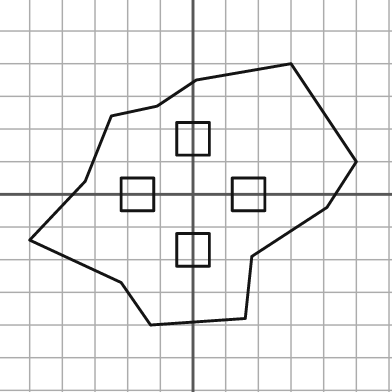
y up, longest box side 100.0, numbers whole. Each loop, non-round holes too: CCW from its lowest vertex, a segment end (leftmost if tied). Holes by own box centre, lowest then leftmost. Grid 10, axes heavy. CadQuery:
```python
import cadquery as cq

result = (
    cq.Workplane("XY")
    .moveTo(-13.0, -40.0)
    .lineTo(16.0, -38.0)
    .lineTo(18.0, -19.0)
    .lineTo(41.0, -4.0)
    .lineTo(50.0, 10.0)
    .lineTo(30.0, 40.0)
    .lineTo(1.0, 35.0)
    .lineTo(-11.0, 27.0)
    .lineTo(-25.0, 24.0)
    .lineTo(-33.0, 4.0)
    .lineTo(-50.0, -14.0)
    .lineTo(-22.0, -27.0)
    .close()
    .moveTo(-5.0, -22.0)
    .lineTo(5.0, -22.0)
    .lineTo(5.0, -12.0)
    .lineTo(-5.0, -12.0)
    .close()
    .moveTo(-22.0, -5.0)
    .lineTo(-12.0, -5.0)
    .lineTo(-12.0, 5.0)
    .lineTo(-22.0, 5.0)
    .close()
    .moveTo(12.0, -5.0)
    .lineTo(22.0, -5.0)
    .lineTo(22.0, 5.0)
    .lineTo(12.0, 5.0)
    .close()
    .moveTo(-5.0, 12.0)
    .lineTo(5.0, 12.0)
    .lineTo(5.0, 22.0)
    .lineTo(-5.0, 22.0)
    .close()
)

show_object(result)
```